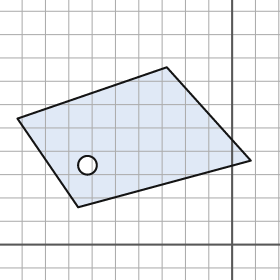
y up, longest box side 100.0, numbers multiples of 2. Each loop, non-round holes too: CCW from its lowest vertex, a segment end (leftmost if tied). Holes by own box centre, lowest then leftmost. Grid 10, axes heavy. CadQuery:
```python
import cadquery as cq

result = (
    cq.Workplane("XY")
    .moveTo(-66.0, 16.0)
    .lineTo(8.0, 36.0)
    .lineTo(-28.0, 76.0)
    .lineTo(-92.0, 54.0)
    .close()
    .moveTo(-62.0, 34.0)
    .circle(4.0)
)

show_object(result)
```